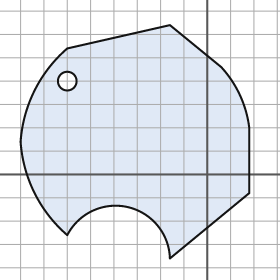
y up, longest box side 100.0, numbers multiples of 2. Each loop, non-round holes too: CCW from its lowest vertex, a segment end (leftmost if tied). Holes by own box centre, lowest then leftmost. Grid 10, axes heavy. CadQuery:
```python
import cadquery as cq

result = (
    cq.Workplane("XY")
    .moveTo(-16.0, -36.0)
    .lineTo(18.0, -8.0)
    .lineTo(18.0, 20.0)
    .threePointArc((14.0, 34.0), (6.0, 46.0))
    .lineTo(-16.0, 64.0)
    .lineTo(-60.0, 54.0)
    .threePointArc((-74.0, 36.0), (-80.0, 14.0))
    .threePointArc((-74.0, -8.0), (-60.0, -26.0))
    .threePointArc((-34.0, -14.0), (-16.0, -36.0))
    .close()
    .moveTo(-60.0, 40.0)
    .circle(4.0)
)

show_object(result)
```